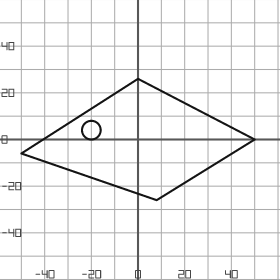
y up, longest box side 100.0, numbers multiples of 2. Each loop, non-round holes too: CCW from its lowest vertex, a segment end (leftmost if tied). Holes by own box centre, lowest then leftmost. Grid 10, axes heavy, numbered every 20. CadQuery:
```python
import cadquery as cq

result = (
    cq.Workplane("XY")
    .moveTo(8.0, -26.0)
    .lineTo(50.0, 0.0)
    .lineTo(0.0, 26.0)
    .lineTo(-50.0, -6.0)
    .close()
    .moveTo(-20.0, 4.0)
    .circle(4.0)
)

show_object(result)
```